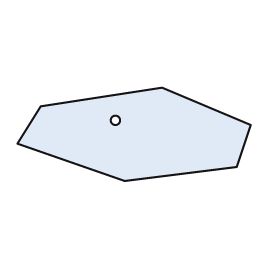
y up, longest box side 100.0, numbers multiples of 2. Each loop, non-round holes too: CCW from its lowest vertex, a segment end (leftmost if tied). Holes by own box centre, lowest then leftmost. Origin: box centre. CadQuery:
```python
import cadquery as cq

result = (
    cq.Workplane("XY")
    .moveTo(-4.0, -20.0)
    .lineTo(44.0, -14.0)
    .lineTo(50.0, 4.0)
    .lineTo(12.0, 20.0)
    .lineTo(-40.0, 12.0)
    .lineTo(-50.0, -4.0)
    .close()
    .moveTo(-8.0, 6.0)
    .circle(2.0)
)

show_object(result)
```